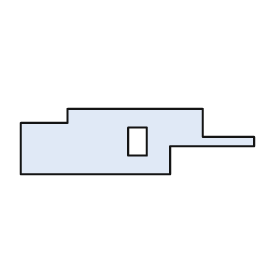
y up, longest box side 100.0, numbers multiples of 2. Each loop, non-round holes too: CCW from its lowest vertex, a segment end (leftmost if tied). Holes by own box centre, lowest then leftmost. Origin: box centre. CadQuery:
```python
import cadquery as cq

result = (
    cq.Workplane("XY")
    .moveTo(-50.0, -14.0)
    .lineTo(14.0, -14.0)
    .lineTo(14.0, -2.0)
    .lineTo(50.0, -2.0)
    .lineTo(50.0, 2.0)
    .lineTo(28.0, 2.0)
    .lineTo(28.0, 14.0)
    .lineTo(-30.0, 14.0)
    .lineTo(-30.0, 8.0)
    .lineTo(-50.0, 8.0)
    .close()
    .moveTo(-4.0, -6.0)
    .lineTo(4.0, -6.0)
    .lineTo(4.0, 6.0)
    .lineTo(-4.0, 6.0)
    .close()
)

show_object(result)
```